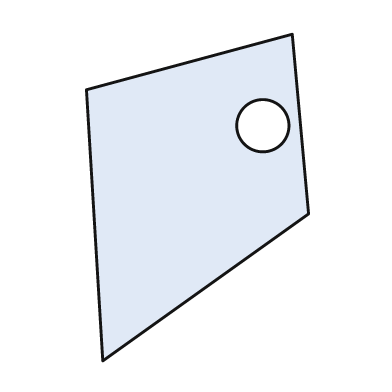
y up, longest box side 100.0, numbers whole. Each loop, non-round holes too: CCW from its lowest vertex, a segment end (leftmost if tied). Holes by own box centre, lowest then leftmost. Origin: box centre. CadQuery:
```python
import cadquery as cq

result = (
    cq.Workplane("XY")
    .moveTo(-29.0, -50.0)
    .lineTo(34.0, -5.0)
    .lineTo(29.0, 50.0)
    .lineTo(-34.0, 33.0)
    .close()
    .moveTo(20.0, 22.0)
    .circle(8.0)
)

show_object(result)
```